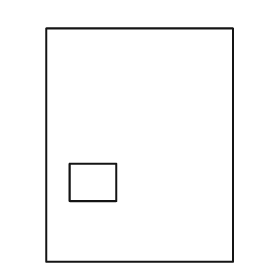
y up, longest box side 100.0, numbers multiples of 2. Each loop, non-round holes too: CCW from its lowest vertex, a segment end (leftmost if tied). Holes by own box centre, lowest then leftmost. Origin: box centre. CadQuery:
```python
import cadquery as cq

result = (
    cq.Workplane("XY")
    .moveTo(-40.0, -50.0)
    .lineTo(40.0, -50.0)
    .lineTo(40.0, 50.0)
    .lineTo(-40.0, 50.0)
    .close()
    .moveTo(-30.0, -24.0)
    .lineTo(-10.0, -24.0)
    .lineTo(-10.0, -8.0)
    .lineTo(-30.0, -8.0)
    .close()
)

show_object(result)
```